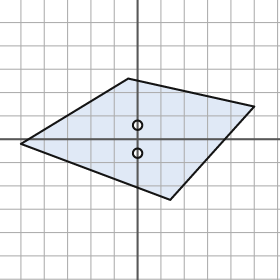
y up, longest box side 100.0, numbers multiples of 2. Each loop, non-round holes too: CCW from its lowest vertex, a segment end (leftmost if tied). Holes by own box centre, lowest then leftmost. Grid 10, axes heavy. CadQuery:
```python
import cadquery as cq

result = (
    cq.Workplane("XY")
    .moveTo(14.0, -26.0)
    .lineTo(50.0, 14.0)
    .lineTo(-4.0, 26.0)
    .lineTo(-50.0, -2.0)
    .close()
    .moveTo(0.0, -6.0)
    .circle(2.0)
    .moveTo(0.0, 6.0)
    .circle(2.0)
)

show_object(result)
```